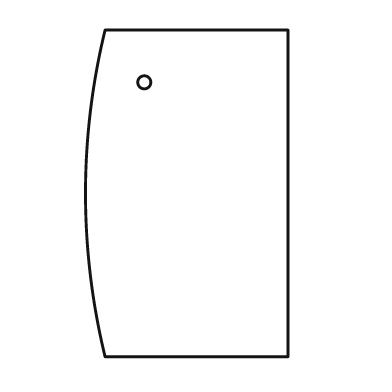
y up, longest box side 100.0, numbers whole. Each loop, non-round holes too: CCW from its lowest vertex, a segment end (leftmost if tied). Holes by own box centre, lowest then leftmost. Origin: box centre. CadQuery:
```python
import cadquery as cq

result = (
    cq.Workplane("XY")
    .moveTo(-25.0, -50.0)
    .lineTo(31.0, -50.0)
    .lineTo(31.0, 50.0)
    .lineTo(-25.0, 50.0)
    .threePointArc((-31.0, 0.0), (-25.0, -50.0))
    .close()
    .moveTo(-13.0, 34.0)
    .circle(2.0)
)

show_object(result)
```